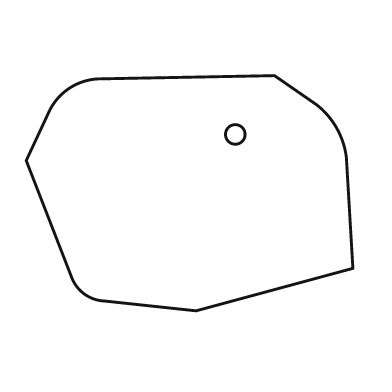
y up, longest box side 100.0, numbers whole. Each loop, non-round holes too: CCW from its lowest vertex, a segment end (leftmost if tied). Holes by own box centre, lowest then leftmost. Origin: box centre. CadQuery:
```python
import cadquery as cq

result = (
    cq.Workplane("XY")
    .moveTo(2.0, -36.0)
    .lineTo(50.0, -23.0)
    .lineTo(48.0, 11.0)
    .threePointArc((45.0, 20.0), (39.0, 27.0))
    .lineTo(26.0, 36.0)
    .lineTo(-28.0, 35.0)
    .threePointArc((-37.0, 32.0), (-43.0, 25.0))
    .lineTo(-50.0, 10.0)
    .lineTo(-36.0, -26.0)
    .threePointArc((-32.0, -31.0), (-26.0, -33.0))
    .close()
    .moveTo(14.0, 18.0)
    .circle(3.0)
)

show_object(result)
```